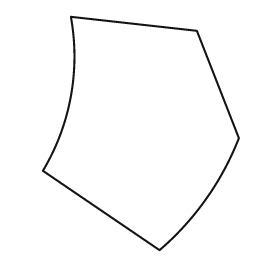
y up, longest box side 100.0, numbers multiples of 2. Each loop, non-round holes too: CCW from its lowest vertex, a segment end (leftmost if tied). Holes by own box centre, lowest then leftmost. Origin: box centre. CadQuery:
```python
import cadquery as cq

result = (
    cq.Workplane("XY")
    .moveTo(8.0, -50.0)
    .threePointArc((28.0, -28.0), (42.0, -2.0))
    .lineTo(24.0, 44.0)
    .lineTo(-30.0, 50.0)
    .threePointArc((-30.0, 16.0), (-42.0, -16.0))
    .close()
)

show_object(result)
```